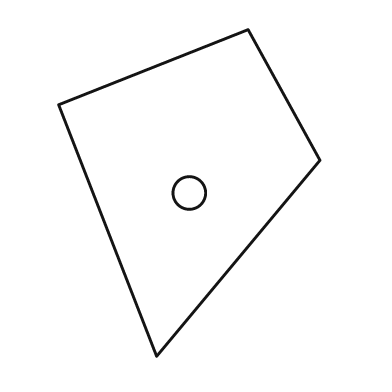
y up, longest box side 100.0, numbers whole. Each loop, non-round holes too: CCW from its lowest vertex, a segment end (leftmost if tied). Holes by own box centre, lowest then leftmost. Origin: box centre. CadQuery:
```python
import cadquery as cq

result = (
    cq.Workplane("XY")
    .moveTo(-10.0, -50.0)
    .lineTo(40.0, 10.0)
    .lineTo(18.0, 50.0)
    .lineTo(-40.0, 27.0)
    .close()
    .moveTo(0.0, 0.0)
    .circle(5.0)
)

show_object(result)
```